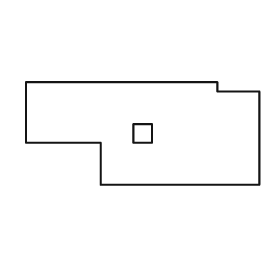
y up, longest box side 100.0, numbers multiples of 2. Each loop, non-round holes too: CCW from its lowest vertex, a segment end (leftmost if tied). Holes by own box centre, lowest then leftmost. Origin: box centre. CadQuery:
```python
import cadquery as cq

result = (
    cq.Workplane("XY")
    .moveTo(-18.0, -22.0)
    .lineTo(50.0, -22.0)
    .lineTo(50.0, 18.0)
    .lineTo(32.0, 18.0)
    .lineTo(32.0, 22.0)
    .lineTo(-50.0, 22.0)
    .lineTo(-50.0, -4.0)
    .lineTo(-18.0, -4.0)
    .close()
    .moveTo(-4.0, -4.0)
    .lineTo(4.0, -4.0)
    .lineTo(4.0, 4.0)
    .lineTo(-4.0, 4.0)
    .close()
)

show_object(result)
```